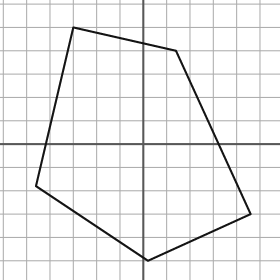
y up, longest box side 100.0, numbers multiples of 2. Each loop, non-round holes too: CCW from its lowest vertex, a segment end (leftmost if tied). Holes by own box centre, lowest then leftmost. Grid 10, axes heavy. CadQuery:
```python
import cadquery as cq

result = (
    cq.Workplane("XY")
    .moveTo(2.0, -50.0)
    .lineTo(46.0, -30.0)
    .lineTo(14.0, 40.0)
    .lineTo(-30.0, 50.0)
    .lineTo(-46.0, -18.0)
    .close()
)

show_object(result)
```